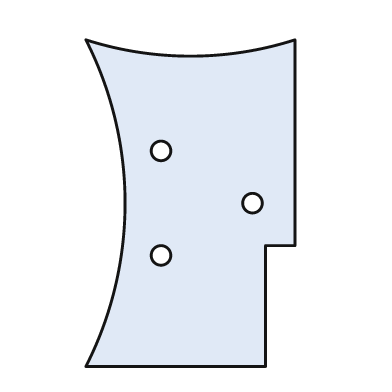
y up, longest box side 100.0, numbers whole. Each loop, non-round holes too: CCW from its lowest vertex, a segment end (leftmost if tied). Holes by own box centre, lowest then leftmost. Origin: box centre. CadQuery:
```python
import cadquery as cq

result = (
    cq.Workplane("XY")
    .moveTo(-32.0, -50.0)
    .lineTo(23.0, -50.0)
    .lineTo(23.0, -13.0)
    .lineTo(32.0, -13.0)
    .lineTo(32.0, 50.0)
    .threePointArc((0.0, 45.0), (-32.0, 50.0))
    .threePointArc((-20.0, 0.0), (-32.0, -50.0))
    .close()
    .moveTo(-9.0, -16.0)
    .circle(3.0)
    .moveTo(19.0, 0.0)
    .circle(3.0)
    .moveTo(-9.0, 16.0)
    .circle(3.0)
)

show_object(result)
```